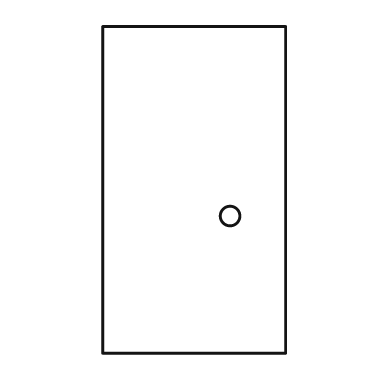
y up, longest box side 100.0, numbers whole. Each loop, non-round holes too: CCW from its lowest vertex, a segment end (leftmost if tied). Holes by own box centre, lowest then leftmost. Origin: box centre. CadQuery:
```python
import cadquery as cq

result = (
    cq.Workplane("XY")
    .moveTo(-28.0, -50.0)
    .lineTo(28.0, -50.0)
    .lineTo(28.0, 50.0)
    .lineTo(-28.0, 50.0)
    .close()
    .moveTo(11.0, -8.0)
    .circle(3.0)
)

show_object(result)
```